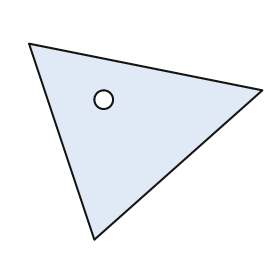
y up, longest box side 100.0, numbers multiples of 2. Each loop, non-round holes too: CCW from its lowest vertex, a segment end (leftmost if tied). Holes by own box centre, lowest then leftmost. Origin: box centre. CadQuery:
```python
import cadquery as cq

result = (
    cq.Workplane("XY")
    .moveTo(-22.0, -42.0)
    .lineTo(50.0, 22.0)
    .lineTo(-50.0, 42.0)
    .close()
    .moveTo(-18.0, 18.0)
    .circle(4.0)
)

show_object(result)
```